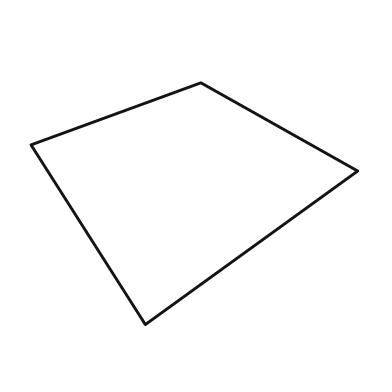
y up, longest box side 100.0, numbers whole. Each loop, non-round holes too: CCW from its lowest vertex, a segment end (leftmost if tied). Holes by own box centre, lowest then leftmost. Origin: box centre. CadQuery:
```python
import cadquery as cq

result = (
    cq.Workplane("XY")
    .moveTo(-15.0, -37.0)
    .lineTo(50.0, 10.0)
    .lineTo(2.0, 37.0)
    .lineTo(-50.0, 18.0)
    .close()
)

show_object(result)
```